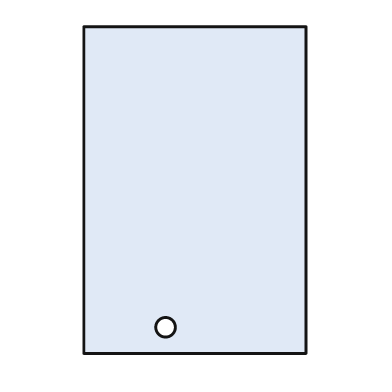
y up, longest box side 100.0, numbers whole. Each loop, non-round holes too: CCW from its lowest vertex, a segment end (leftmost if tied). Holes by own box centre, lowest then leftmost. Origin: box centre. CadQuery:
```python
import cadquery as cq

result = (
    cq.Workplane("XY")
    .moveTo(-34.0, -50.0)
    .lineTo(34.0, -50.0)
    .lineTo(34.0, 50.0)
    .lineTo(-34.0, 50.0)
    .close()
    .moveTo(-9.0, -42.0)
    .circle(3.0)
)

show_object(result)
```